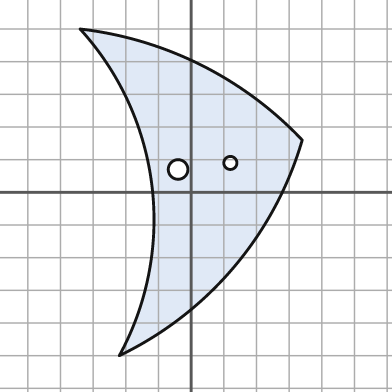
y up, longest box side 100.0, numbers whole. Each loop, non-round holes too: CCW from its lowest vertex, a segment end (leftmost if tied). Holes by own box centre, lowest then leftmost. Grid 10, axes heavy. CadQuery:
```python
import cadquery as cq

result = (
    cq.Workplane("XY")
    .moveTo(-22.0, -50.0)
    .threePointArc((13.0, -23.0), (34.0, 16.0))
    .threePointArc((3.0, 39.0), (-34.0, 50.0))
    .threePointArc((-12.0, 2.0), (-22.0, -50.0))
    .close()
    .moveTo(-4.0, 7.0)
    .circle(3.0)
    .moveTo(12.0, 9.0)
    .circle(2.0)
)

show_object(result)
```